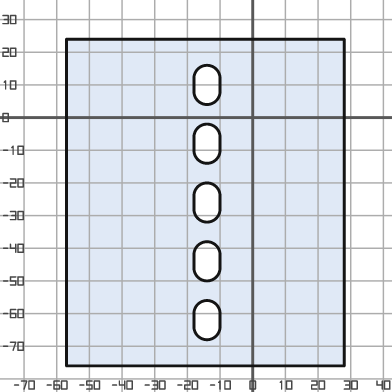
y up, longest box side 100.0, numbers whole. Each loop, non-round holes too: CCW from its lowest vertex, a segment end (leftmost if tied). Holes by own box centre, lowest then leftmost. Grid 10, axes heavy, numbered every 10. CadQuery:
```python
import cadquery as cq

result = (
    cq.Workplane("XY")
    .moveTo(-57.0, -76.0)
    .lineTo(28.0, -76.0)
    .lineTo(28.0, 24.0)
    .lineTo(-57.0, 24.0)
    .close()
    .moveTo(-18.0, -64.0)
    .threePointArc((-14.0, -68.0), (-10.0, -64.0))
    .lineTo(-10.0, -60.0)
    .threePointArc((-14.0, -56.0), (-18.0, -60.0))
    .close()
    .moveTo(-18.0, -46.0)
    .threePointArc((-14.0, -50.0), (-10.0, -46.0))
    .lineTo(-10.0, -42.0)
    .threePointArc((-14.0, -38.0), (-18.0, -42.0))
    .close()
    .moveTo(-18.0, -28.0)
    .threePointArc((-14.0, -32.0), (-10.0, -28.0))
    .lineTo(-10.0, -24.0)
    .threePointArc((-14.0, -20.0), (-18.0, -24.0))
    .close()
    .moveTo(-18.0, -10.0)
    .threePointArc((-14.0, -14.0), (-10.0, -10.0))
    .lineTo(-10.0, -6.0)
    .threePointArc((-14.0, -2.0), (-18.0, -6.0))
    .close()
    .moveTo(-18.0, 8.0)
    .threePointArc((-14.0, 4.0), (-10.0, 8.0))
    .lineTo(-10.0, 12.0)
    .threePointArc((-14.0, 16.0), (-18.0, 12.0))
    .close()
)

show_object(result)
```